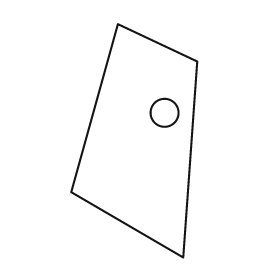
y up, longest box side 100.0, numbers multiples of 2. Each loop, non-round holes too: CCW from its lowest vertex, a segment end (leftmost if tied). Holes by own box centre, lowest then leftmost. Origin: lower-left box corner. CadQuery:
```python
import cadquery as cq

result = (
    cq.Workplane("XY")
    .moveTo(48.0, 0.0)
    .lineTo(54.0, 84.0)
    .lineTo(20.0, 100.0)
    .lineTo(0.0, 28.0)
    .close()
    .moveTo(40.0, 62.0)
    .circle(6.0)
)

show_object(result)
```